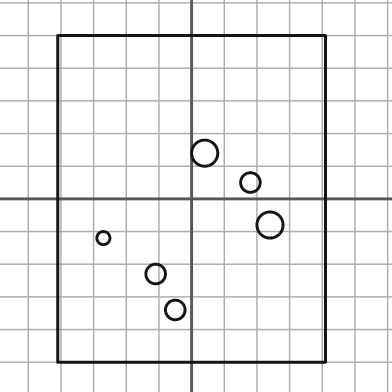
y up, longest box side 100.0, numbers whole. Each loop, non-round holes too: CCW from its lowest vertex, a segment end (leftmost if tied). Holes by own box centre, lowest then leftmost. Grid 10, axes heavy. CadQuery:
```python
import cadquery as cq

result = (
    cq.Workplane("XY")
    .moveTo(-41.0, -50.0)
    .lineTo(41.0, -50.0)
    .lineTo(41.0, 50.0)
    .lineTo(-41.0, 50.0)
    .close()
    .moveTo(-5.0, -34.0)
    .circle(3.0)
    .moveTo(-11.0, -23.0)
    .circle(3.0)
    .moveTo(-27.0, -12.0)
    .circle(2.0)
    .moveTo(24.0, -8.0)
    .circle(4.0)
    .moveTo(18.0, 5.0)
    .circle(3.0)
    .moveTo(4.0, 14.0)
    .circle(4.0)
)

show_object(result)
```